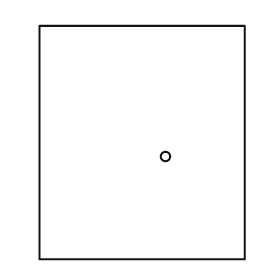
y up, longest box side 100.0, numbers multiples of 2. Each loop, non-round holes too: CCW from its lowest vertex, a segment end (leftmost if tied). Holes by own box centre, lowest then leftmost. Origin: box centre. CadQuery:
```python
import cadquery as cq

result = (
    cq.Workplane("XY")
    .moveTo(-44.0, -50.0)
    .lineTo(44.0, -50.0)
    .lineTo(44.0, 50.0)
    .lineTo(-44.0, 50.0)
    .close()
    .moveTo(10.0, -6.0)
    .circle(2.0)
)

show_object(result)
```